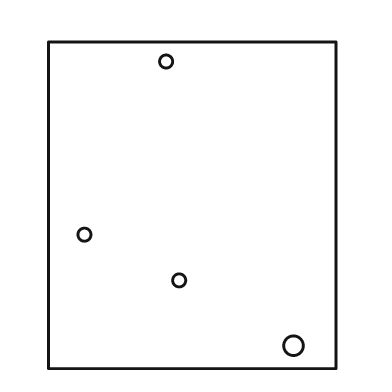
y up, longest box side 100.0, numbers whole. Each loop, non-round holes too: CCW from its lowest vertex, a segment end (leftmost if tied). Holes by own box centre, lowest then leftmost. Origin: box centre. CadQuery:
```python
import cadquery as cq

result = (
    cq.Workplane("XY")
    .moveTo(-44.0, -50.0)
    .lineTo(44.0, -50.0)
    .lineTo(44.0, 50.0)
    .lineTo(-44.0, 50.0)
    .close()
    .moveTo(31.0, -43.0)
    .circle(3.0)
    .moveTo(-4.0, -23.0)
    .circle(2.0)
    .moveTo(-33.0, -9.0)
    .circle(2.0)
    .moveTo(-8.0, 44.0)
    .circle(2.0)
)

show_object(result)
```